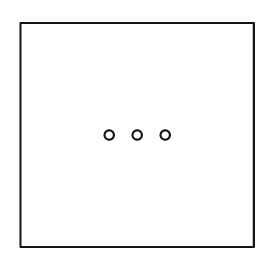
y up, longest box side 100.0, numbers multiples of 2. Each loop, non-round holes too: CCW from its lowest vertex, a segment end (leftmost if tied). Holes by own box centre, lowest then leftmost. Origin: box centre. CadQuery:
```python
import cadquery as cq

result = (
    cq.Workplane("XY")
    .moveTo(-50.0, -48.0)
    .lineTo(50.0, -48.0)
    .lineTo(50.0, 48.0)
    .lineTo(-50.0, 48.0)
    .close()
    .moveTo(-12.0, 0.0)
    .circle(2.0)
    .moveTo(0.0, 0.0)
    .circle(2.0)
    .moveTo(12.0, 0.0)
    .circle(2.0)
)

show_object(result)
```